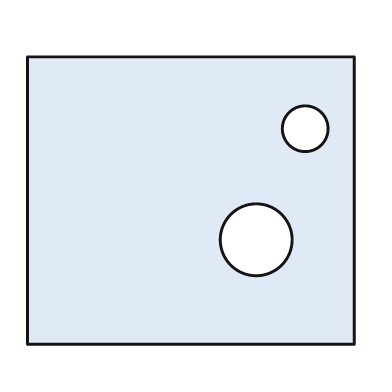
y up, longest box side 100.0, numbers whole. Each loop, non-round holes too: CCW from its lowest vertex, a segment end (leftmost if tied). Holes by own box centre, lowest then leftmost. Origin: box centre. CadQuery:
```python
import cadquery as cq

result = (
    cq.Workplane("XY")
    .moveTo(-50.0, -44.0)
    .lineTo(50.0, -44.0)
    .lineTo(50.0, 44.0)
    .lineTo(-50.0, 44.0)
    .close()
    .moveTo(20.0, -12.0)
    .circle(11.0)
    .moveTo(35.0, 22.0)
    .circle(7.0)
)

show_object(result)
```